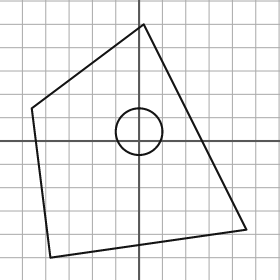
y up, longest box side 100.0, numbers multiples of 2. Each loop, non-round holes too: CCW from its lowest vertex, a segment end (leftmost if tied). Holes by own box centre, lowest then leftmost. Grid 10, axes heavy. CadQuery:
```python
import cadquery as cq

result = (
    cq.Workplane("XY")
    .moveTo(-38.0, -50.0)
    .lineTo(46.0, -38.0)
    .lineTo(2.0, 50.0)
    .lineTo(-46.0, 14.0)
    .close()
    .moveTo(0.0, 4.0)
    .circle(10.0)
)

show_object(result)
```